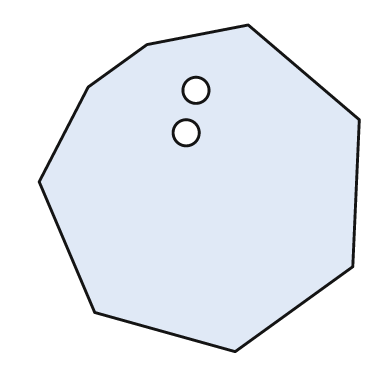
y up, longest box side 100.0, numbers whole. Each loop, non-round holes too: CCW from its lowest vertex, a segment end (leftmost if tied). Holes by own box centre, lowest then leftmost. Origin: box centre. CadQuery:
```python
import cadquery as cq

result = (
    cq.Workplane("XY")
    .moveTo(11.0, -50.0)
    .lineTo(47.0, -24.0)
    .lineTo(49.0, 21.0)
    .lineTo(15.0, 50.0)
    .lineTo(-16.0, 44.0)
    .lineTo(-34.0, 31.0)
    .lineTo(-49.0, 2.0)
    .lineTo(-32.0, -38.0)
    .close()
    .moveTo(-4.0, 17.0)
    .circle(4.0)
    .moveTo(-1.0, 30.0)
    .circle(4.0)
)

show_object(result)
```